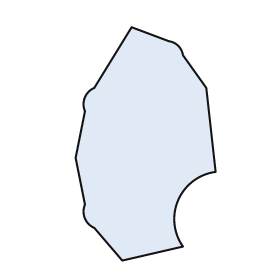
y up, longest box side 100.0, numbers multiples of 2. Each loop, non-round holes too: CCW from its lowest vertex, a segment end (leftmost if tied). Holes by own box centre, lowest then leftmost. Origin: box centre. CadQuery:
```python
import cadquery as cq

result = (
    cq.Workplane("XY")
    .moveTo(-10.0, -50.0)
    .lineTo(16.0, -44.0)
    .threePointArc((14.0, -24.0), (30.0, -12.0))
    .lineTo(26.0, 24.0)
    .lineTo(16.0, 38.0)
    .threePointArc((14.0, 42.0), (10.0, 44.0))
    .lineTo(-6.0, 50.0)
    .lineTo(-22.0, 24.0)
    .threePointArc((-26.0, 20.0), (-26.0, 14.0))
    .lineTo(-30.0, -6.0)
    .lineTo(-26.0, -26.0)
    .threePointArc((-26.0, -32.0), (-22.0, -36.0))
    .close()
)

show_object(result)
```